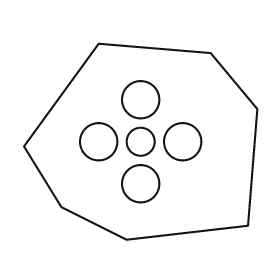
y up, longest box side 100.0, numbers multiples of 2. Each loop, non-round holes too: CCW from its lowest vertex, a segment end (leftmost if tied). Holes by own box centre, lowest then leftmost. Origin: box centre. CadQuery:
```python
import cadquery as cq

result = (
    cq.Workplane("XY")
    .moveTo(-6.0, -42.0)
    .lineTo(46.0, -36.0)
    .lineTo(50.0, 14.0)
    .lineTo(30.0, 38.0)
    .lineTo(-18.0, 42.0)
    .lineTo(-50.0, -2.0)
    .lineTo(-34.0, -28.0)
    .close()
    .moveTo(0.0, -18.0)
    .circle(8.0)
    .moveTo(-18.0, 0.0)
    .circle(8.0)
    .moveTo(0.0, 0.0)
    .circle(6.0)
    .moveTo(18.0, 0.0)
    .circle(8.0)
    .moveTo(0.0, 18.0)
    .circle(8.0)
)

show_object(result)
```